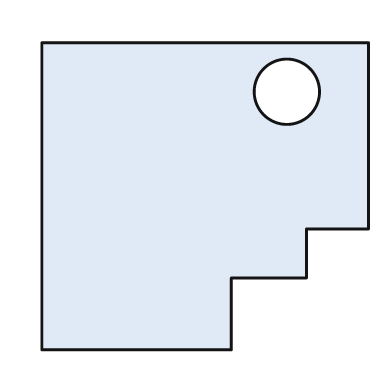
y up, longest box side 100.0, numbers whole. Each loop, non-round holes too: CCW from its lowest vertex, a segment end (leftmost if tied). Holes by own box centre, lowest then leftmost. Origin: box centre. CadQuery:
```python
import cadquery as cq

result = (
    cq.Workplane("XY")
    .moveTo(-50.0, -47.0)
    .lineTo(8.0, -47.0)
    .lineTo(8.0, -25.0)
    .lineTo(31.0, -25.0)
    .lineTo(31.0, -10.0)
    .lineTo(50.0, -10.0)
    .lineTo(50.0, 47.0)
    .lineTo(-50.0, 47.0)
    .close()
    .moveTo(25.0, 32.0)
    .circle(10.0)
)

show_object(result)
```